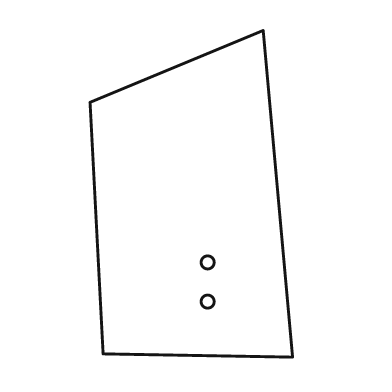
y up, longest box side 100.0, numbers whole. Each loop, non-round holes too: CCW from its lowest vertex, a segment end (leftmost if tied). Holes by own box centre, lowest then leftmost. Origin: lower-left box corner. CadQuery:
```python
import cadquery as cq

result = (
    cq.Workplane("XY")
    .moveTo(62.0, 0.0)
    .lineTo(53.0, 100.0)
    .lineTo(0.0, 78.0)
    .lineTo(4.0, 1.0)
    .close()
    .moveTo(36.0, 17.0)
    .circle(2.0)
    .moveTo(36.0, 29.0)
    .circle(2.0)
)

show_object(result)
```